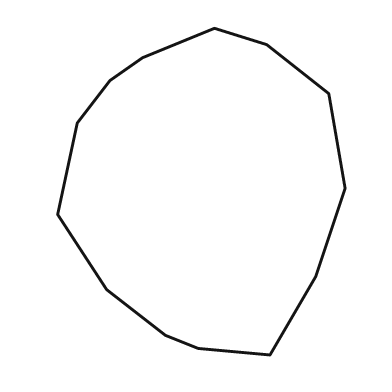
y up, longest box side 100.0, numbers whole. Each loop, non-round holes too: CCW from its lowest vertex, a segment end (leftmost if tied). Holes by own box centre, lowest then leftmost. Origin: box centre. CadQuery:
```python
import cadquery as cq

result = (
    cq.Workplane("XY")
    .moveTo(21.0, -50.0)
    .lineTo(35.0, -26.0)
    .lineTo(44.0, 1.0)
    .lineTo(39.0, 30.0)
    .lineTo(20.0, 45.0)
    .lineTo(4.0, 50.0)
    .lineTo(-18.0, 41.0)
    .lineTo(-28.0, 34.0)
    .lineTo(-38.0, 21.0)
    .lineTo(-44.0, -7.0)
    .lineTo(-29.0, -30.0)
    .lineTo(-11.0, -44.0)
    .lineTo(-1.0, -48.0)
    .close()
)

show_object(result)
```